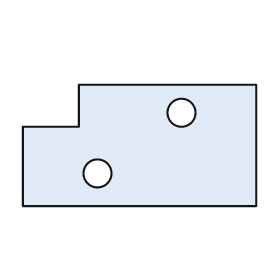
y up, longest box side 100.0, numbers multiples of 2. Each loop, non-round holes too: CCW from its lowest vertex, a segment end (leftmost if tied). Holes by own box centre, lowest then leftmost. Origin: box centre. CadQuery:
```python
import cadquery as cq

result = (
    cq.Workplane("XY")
    .moveTo(-50.0, -26.0)
    .lineTo(50.0, -26.0)
    .lineTo(50.0, 26.0)
    .lineTo(-26.0, 26.0)
    .lineTo(-26.0, 8.0)
    .lineTo(-50.0, 8.0)
    .close()
    .moveTo(-18.0, -12.0)
    .circle(6.0)
    .moveTo(18.0, 14.0)
    .circle(6.0)
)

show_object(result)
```